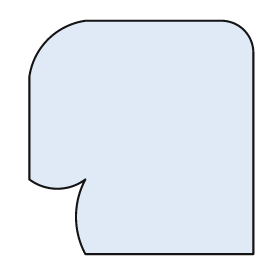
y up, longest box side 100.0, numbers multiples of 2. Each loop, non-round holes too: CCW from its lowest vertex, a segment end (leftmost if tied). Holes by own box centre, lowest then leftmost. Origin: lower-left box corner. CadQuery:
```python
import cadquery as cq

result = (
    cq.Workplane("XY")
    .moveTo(24.0, 0.0)
    .lineTo(96.0, 0.0)
    .lineTo(96.0, 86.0)
    .threePointArc((92.0, 96.0), (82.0, 100.0))
    .lineTo(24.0, 100.0)
    .threePointArc((8.0, 92.0), (0.0, 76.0))
    .lineTo(0.0, 32.0)
    .threePointArc((12.0, 28.0), (24.0, 32.0))
    .threePointArc((20.0, 16.0), (24.0, 0.0))
    .close()
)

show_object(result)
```